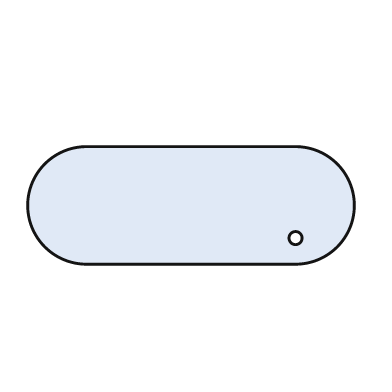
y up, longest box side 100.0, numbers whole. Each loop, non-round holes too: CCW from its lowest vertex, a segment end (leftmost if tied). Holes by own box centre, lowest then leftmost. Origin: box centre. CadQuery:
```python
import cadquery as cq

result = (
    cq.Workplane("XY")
    .moveTo(-32.0, -18.0)
    .lineTo(32.0, -18.0)
    .threePointArc((50.0, 0.0), (32.0, 18.0))
    .lineTo(-32.0, 18.0)
    .threePointArc((-50.0, 0.0), (-32.0, -18.0))
    .close()
    .moveTo(32.0, -10.0)
    .circle(2.0)
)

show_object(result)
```